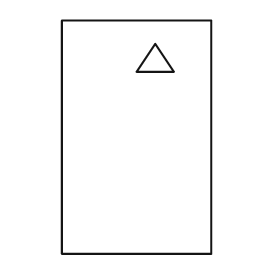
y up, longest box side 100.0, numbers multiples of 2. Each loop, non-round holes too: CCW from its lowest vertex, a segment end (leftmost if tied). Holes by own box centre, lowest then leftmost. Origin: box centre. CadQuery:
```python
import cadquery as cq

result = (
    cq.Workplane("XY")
    .moveTo(-32.0, -50.0)
    .lineTo(32.0, -50.0)
    .lineTo(32.0, 50.0)
    .lineTo(-32.0, 50.0)
    .close()
    .moveTo(0.0, 28.0)
    .lineTo(16.0, 28.0)
    .lineTo(8.0, 40.0)
    .close()
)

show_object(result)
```